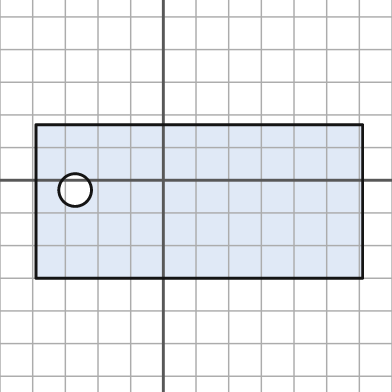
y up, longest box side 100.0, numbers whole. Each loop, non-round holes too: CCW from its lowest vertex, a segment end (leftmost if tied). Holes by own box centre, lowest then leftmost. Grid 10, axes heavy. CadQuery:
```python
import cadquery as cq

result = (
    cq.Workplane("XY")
    .moveTo(-39.0, -30.0)
    .lineTo(61.0, -30.0)
    .lineTo(61.0, 17.0)
    .lineTo(-39.0, 17.0)
    .close()
    .moveTo(-27.0, -3.0)
    .circle(5.0)
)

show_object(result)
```